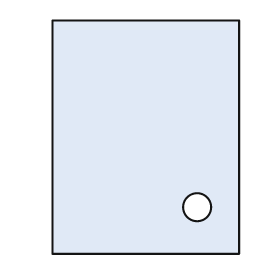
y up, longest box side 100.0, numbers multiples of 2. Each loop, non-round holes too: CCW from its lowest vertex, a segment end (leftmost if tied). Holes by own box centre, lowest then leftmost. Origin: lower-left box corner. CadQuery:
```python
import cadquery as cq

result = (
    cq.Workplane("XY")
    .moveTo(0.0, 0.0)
    .lineTo(80.0, 0.0)
    .lineTo(80.0, 100.0)
    .lineTo(0.0, 100.0)
    .close()
    .moveTo(62.0, 20.0)
    .circle(6.0)
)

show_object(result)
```